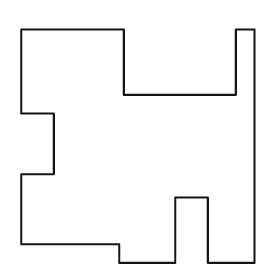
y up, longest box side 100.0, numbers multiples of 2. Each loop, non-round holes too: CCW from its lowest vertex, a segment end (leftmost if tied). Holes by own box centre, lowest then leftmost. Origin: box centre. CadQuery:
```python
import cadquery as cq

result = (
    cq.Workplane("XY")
    .moveTo(-8.0, -50.0)
    .lineTo(16.0, -50.0)
    .lineTo(16.0, -22.0)
    .lineTo(30.0, -22.0)
    .lineTo(30.0, -50.0)
    .lineTo(50.0, -50.0)
    .lineTo(50.0, 50.0)
    .lineTo(42.0, 50.0)
    .lineTo(42.0, 22.0)
    .lineTo(-6.0, 22.0)
    .lineTo(-6.0, 50.0)
    .lineTo(-50.0, 50.0)
    .lineTo(-50.0, 14.0)
    .lineTo(-36.0, 14.0)
    .lineTo(-36.0, -12.0)
    .lineTo(-50.0, -12.0)
    .lineTo(-50.0, -42.0)
    .lineTo(-8.0, -42.0)
    .close()
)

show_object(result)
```